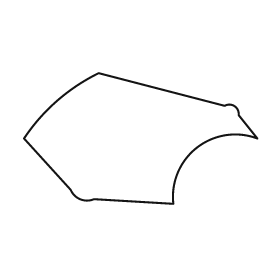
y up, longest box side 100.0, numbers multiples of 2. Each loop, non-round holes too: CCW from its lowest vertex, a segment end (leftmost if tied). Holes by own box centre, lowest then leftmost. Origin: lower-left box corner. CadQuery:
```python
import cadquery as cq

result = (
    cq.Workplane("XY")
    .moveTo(64.0, 0.0)
    .threePointArc((74.0, 24.0), (100.0, 28.0))
    .lineTo(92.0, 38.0)
    .threePointArc((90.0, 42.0), (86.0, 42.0))
    .lineTo(32.0, 56.0)
    .threePointArc((14.0, 44.0), (0.0, 28.0))
    .lineTo(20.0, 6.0)
    .threePointArc((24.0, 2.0), (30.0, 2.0))
    .close()
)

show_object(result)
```